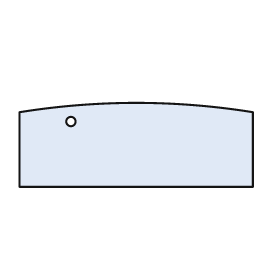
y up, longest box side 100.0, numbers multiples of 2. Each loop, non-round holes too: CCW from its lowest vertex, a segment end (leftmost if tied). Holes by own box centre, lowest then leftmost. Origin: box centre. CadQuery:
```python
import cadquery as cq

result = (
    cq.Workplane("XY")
    .moveTo(-50.0, -18.0)
    .lineTo(50.0, -18.0)
    .lineTo(50.0, 14.0)
    .threePointArc((0.0, 18.0), (-50.0, 14.0))
    .close()
    .moveTo(-28.0, 10.0)
    .circle(2.0)
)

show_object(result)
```